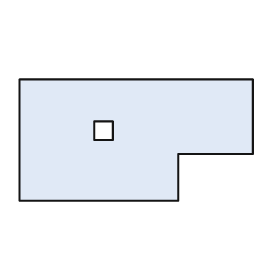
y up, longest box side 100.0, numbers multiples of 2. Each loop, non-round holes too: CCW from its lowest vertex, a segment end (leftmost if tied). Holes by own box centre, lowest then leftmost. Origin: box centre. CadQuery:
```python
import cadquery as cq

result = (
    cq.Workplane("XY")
    .moveTo(-50.0, -26.0)
    .lineTo(18.0, -26.0)
    .lineTo(18.0, -6.0)
    .lineTo(50.0, -6.0)
    .lineTo(50.0, 26.0)
    .lineTo(-50.0, 26.0)
    .close()
    .moveTo(-18.0, 0.0)
    .lineTo(-10.0, 0.0)
    .lineTo(-10.0, 8.0)
    .lineTo(-18.0, 8.0)
    .close()
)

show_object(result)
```